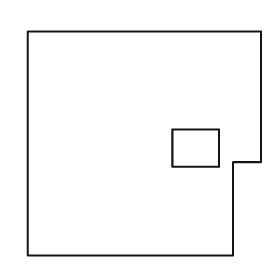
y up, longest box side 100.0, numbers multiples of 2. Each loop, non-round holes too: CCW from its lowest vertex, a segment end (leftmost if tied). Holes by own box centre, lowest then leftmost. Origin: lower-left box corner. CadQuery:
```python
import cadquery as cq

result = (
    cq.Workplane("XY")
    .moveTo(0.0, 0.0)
    .lineTo(88.0, 0.0)
    .lineTo(88.0, 40.0)
    .lineTo(100.0, 40.0)
    .lineTo(100.0, 96.0)
    .lineTo(0.0, 96.0)
    .close()
    .moveTo(62.0, 38.0)
    .lineTo(82.0, 38.0)
    .lineTo(82.0, 54.0)
    .lineTo(62.0, 54.0)
    .close()
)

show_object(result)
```